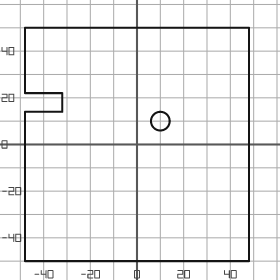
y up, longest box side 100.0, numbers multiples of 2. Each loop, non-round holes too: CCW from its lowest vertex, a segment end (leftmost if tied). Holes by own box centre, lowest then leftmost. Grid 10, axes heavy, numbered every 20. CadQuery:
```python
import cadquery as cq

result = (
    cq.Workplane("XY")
    .moveTo(-48.0, -50.0)
    .lineTo(48.0, -50.0)
    .lineTo(48.0, 50.0)
    .lineTo(-48.0, 50.0)
    .lineTo(-48.0, 22.0)
    .lineTo(-32.0, 22.0)
    .lineTo(-32.0, 14.0)
    .lineTo(-48.0, 14.0)
    .close()
    .moveTo(10.0, 10.0)
    .circle(4.0)
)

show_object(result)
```